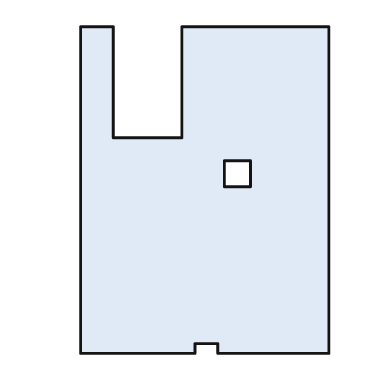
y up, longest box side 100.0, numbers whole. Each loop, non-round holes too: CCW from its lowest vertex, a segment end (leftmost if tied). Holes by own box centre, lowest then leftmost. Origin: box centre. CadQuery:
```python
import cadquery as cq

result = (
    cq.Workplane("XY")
    .moveTo(-38.0, -50.0)
    .lineTo(-3.0, -50.0)
    .lineTo(-3.0, -47.0)
    .lineTo(4.0, -47.0)
    .lineTo(4.0, -50.0)
    .lineTo(38.0, -50.0)
    .lineTo(38.0, 50.0)
    .lineTo(-7.0, 50.0)
    .lineTo(-7.0, 16.0)
    .lineTo(-28.0, 16.0)
    .lineTo(-28.0, 50.0)
    .lineTo(-38.0, 50.0)
    .close()
    .moveTo(6.0, 1.0)
    .lineTo(14.0, 1.0)
    .lineTo(14.0, 9.0)
    .lineTo(6.0, 9.0)
    .close()
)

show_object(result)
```